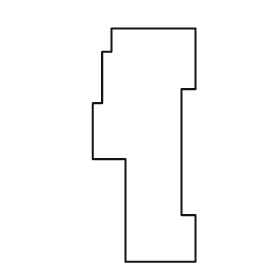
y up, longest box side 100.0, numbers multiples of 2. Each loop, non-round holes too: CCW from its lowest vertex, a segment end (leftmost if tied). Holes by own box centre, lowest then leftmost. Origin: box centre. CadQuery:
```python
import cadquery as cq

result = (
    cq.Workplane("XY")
    .moveTo(-8.0, -50.0)
    .lineTo(22.0, -50.0)
    .lineTo(22.0, -30.0)
    .lineTo(16.0, -30.0)
    .lineTo(16.0, 24.0)
    .lineTo(22.0, 24.0)
    .lineTo(22.0, 50.0)
    .lineTo(-14.0, 50.0)
    .lineTo(-14.0, 40.0)
    .lineTo(-18.0, 40.0)
    .lineTo(-18.0, 18.0)
    .lineTo(-22.0, 18.0)
    .lineTo(-22.0, -6.0)
    .lineTo(-8.0, -6.0)
    .close()
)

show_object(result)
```